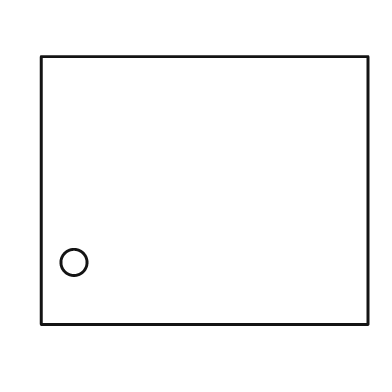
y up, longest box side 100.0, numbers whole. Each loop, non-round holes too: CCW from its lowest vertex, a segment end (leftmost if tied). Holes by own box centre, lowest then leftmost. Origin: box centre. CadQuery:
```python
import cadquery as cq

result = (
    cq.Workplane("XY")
    .moveTo(-50.0, -41.0)
    .lineTo(50.0, -41.0)
    .lineTo(50.0, 41.0)
    .lineTo(-50.0, 41.0)
    .close()
    .moveTo(-40.0, -22.0)
    .circle(4.0)
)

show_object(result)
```